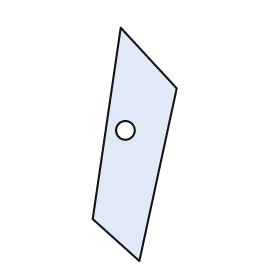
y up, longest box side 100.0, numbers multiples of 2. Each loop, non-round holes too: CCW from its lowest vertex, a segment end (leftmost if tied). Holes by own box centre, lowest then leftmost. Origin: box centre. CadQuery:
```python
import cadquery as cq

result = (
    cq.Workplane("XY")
    .moveTo(2.0, -50.0)
    .lineTo(18.0, 24.0)
    .lineTo(-6.0, 50.0)
    .lineTo(-18.0, -32.0)
    .close()
    .moveTo(-4.0, 6.0)
    .circle(4.0)
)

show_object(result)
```